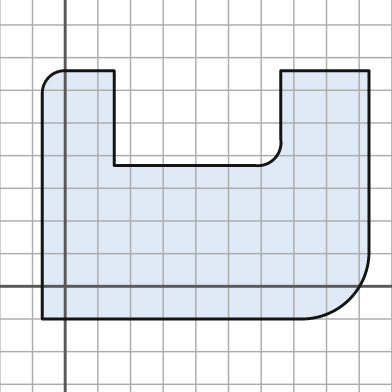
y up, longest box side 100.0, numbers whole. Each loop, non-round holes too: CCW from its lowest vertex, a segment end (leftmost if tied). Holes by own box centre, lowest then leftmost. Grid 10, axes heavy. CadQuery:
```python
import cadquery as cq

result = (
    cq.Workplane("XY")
    .moveTo(-7.0, -10.0)
    .lineTo(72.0, -10.0)
    .threePointArc((87.0, -4.0), (93.0, 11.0))
    .lineTo(93.0, 66.0)
    .lineTo(66.0, 66.0)
    .lineTo(66.0, 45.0)
    .threePointArc((64.0, 39.0), (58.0, 37.0))
    .lineTo(15.0, 37.0)
    .lineTo(15.0, 66.0)
    .lineTo(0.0, 66.0)
    .threePointArc((-5.0, 64.0), (-7.0, 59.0))
    .close()
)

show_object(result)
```